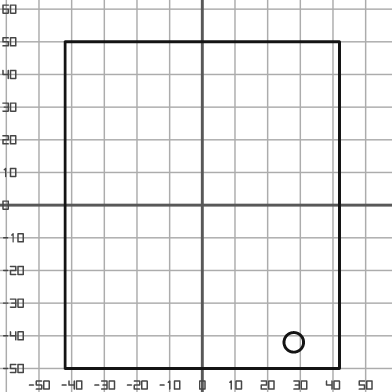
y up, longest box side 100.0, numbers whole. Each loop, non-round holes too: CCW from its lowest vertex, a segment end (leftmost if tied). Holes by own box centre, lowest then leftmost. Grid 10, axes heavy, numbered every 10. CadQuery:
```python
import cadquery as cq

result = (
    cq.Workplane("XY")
    .moveTo(-42.0, -50.0)
    .lineTo(42.0, -50.0)
    .lineTo(42.0, 50.0)
    .lineTo(-42.0, 50.0)
    .close()
    .moveTo(28.0, -42.0)
    .circle(3.0)
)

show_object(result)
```